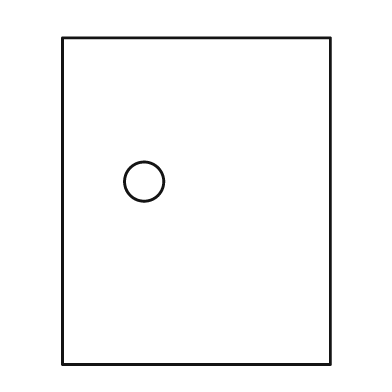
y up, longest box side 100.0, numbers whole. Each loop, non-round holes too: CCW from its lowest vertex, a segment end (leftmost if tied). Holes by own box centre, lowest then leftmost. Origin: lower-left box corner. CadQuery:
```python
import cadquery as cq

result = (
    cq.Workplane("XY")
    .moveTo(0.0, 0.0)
    .lineTo(82.0, 0.0)
    .lineTo(82.0, 100.0)
    .lineTo(0.0, 100.0)
    .close()
    .moveTo(25.0, 56.0)
    .circle(6.0)
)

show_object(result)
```